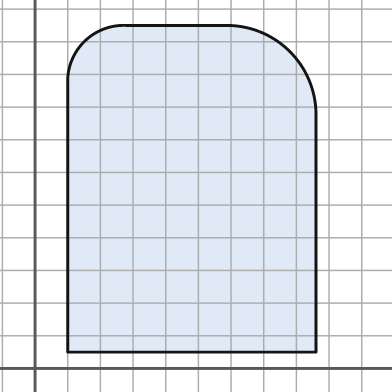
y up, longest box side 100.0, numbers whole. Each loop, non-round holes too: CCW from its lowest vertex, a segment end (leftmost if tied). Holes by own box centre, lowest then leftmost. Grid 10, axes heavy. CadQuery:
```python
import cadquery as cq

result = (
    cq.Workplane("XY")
    .moveTo(10.0, 5.0)
    .lineTo(86.0, 5.0)
    .lineTo(86.0, 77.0)
    .threePointArc((78.0, 97.0), (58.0, 105.0))
    .lineTo(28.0, 105.0)
    .threePointArc((15.0, 100.0), (10.0, 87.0))
    .close()
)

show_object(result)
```